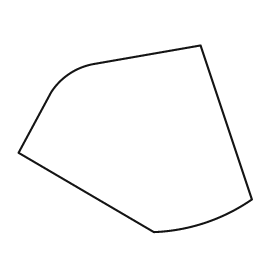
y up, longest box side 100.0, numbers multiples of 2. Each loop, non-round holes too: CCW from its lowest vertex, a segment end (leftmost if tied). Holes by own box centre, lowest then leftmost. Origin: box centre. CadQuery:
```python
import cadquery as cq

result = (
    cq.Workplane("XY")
    .moveTo(8.0, -40.0)
    .threePointArc((30.0, -36.0), (50.0, -26.0))
    .lineTo(28.0, 40.0)
    .lineTo(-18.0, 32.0)
    .threePointArc((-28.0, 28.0), (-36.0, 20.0))
    .lineTo(-50.0, -6.0)
    .close()
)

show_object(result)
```